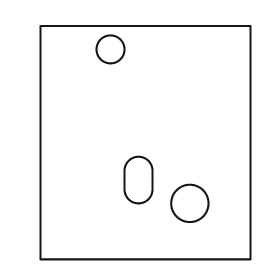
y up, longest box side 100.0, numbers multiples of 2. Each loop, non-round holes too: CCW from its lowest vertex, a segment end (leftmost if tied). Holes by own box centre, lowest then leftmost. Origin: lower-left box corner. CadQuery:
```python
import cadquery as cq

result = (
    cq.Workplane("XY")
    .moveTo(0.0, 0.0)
    .lineTo(90.0, 0.0)
    .lineTo(90.0, 100.0)
    .lineTo(0.0, 100.0)
    .close()
    .moveTo(64.0, 24.0)
    .circle(8.0)
    .moveTo(36.0, 30.0)
    .threePointArc((42.0, 24.0), (48.0, 30.0))
    .lineTo(48.0, 38.0)
    .threePointArc((42.0, 44.0), (36.0, 38.0))
    .close()
    .moveTo(30.0, 90.0)
    .circle(6.0)
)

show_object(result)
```